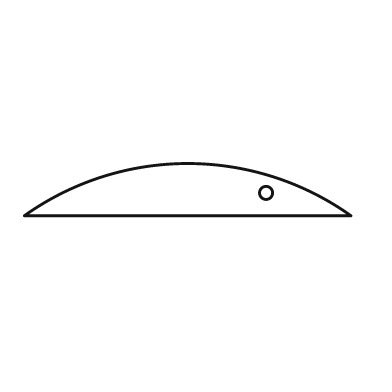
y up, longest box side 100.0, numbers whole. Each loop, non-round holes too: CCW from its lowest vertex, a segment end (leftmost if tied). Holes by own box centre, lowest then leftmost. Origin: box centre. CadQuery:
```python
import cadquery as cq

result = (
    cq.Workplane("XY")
    .moveTo(-50.0, -8.0)
    .lineTo(50.0, -8.0)
    .threePointArc((0.0, 8.0), (-50.0, -8.0))
    .close()
    .moveTo(24.0, -1.0)
    .circle(2.0)
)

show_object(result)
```